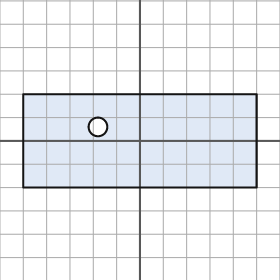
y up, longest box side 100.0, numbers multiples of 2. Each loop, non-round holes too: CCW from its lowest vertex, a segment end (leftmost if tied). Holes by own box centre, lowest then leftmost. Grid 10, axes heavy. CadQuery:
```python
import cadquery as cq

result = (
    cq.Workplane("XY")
    .moveTo(-50.0, -20.0)
    .lineTo(50.0, -20.0)
    .lineTo(50.0, 20.0)
    .lineTo(-50.0, 20.0)
    .close()
    .moveTo(-18.0, 6.0)
    .circle(4.0)
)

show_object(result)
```